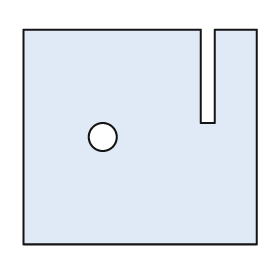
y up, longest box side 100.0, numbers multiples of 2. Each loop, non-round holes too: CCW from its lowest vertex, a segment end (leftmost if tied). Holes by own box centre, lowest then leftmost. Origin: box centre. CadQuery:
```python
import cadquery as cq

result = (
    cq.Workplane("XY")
    .moveTo(-50.0, -46.0)
    .lineTo(50.0, -46.0)
    .lineTo(50.0, 46.0)
    .lineTo(32.0, 46.0)
    .lineTo(32.0, 6.0)
    .lineTo(26.0, 6.0)
    .lineTo(26.0, 46.0)
    .lineTo(-50.0, 46.0)
    .close()
    .moveTo(-16.0, 0.0)
    .circle(6.0)
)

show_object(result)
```